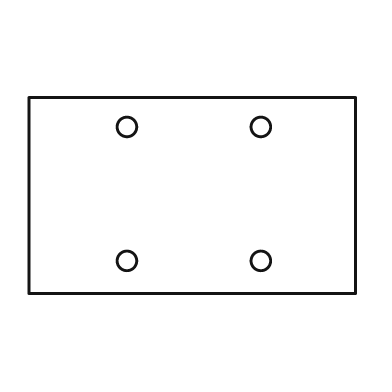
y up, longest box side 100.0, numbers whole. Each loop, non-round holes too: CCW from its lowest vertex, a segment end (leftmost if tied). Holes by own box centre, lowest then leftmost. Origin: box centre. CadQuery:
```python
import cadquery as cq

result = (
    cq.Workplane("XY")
    .moveTo(-50.0, -30.0)
    .lineTo(50.0, -30.0)
    .lineTo(50.0, 30.0)
    .lineTo(-50.0, 30.0)
    .close()
    .moveTo(-20.0, -20.0)
    .circle(3.0)
    .moveTo(21.0, -20.0)
    .circle(3.0)
    .moveTo(-20.0, 21.0)
    .circle(3.0)
    .moveTo(21.0, 21.0)
    .circle(3.0)
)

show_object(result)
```